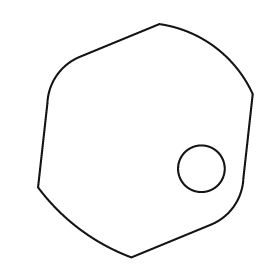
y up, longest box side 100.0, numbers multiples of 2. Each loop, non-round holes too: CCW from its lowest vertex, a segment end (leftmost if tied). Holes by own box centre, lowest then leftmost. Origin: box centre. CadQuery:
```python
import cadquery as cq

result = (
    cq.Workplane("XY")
    .moveTo(-6.0, -50.0)
    .lineTo(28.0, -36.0)
    .threePointArc((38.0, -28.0), (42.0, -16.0))
    .lineTo(46.0, 20.0)
    .threePointArc((30.0, 40.0), (6.0, 50.0))
    .lineTo(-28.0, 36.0)
    .threePointArc((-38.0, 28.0), (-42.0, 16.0))
    .lineTo(-46.0, -20.0)
    .threePointArc((-28.0, -38.0), (-6.0, -50.0))
    .close()
    .moveTo(24.0, -12.0)
    .circle(10.0)
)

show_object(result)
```